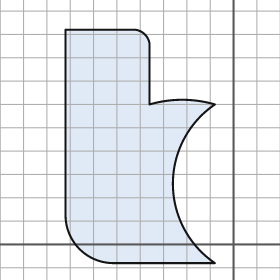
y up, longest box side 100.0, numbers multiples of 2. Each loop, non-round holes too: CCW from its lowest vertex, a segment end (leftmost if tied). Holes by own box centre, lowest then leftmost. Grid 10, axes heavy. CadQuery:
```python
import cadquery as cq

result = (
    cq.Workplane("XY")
    .moveTo(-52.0, -8.0)
    .lineTo(-8.0, -8.0)
    .threePointArc((-26.0, 26.0), (-8.0, 60.0))
    .threePointArc((-22.0, 62.0), (-36.0, 60.0))
    .lineTo(-36.0, 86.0)
    .threePointArc((-38.0, 90.0), (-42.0, 92.0))
    .lineTo(-72.0, 92.0)
    .lineTo(-72.0, 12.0)
    .threePointArc((-66.0, -2.0), (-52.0, -8.0))
    .close()
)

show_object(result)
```